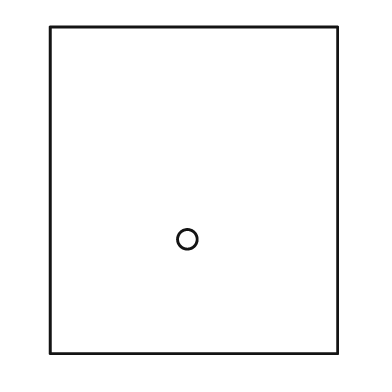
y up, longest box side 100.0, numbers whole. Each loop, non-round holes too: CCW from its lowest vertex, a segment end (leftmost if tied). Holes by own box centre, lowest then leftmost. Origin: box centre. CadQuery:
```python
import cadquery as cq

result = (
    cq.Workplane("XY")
    .moveTo(-44.0, -50.0)
    .lineTo(44.0, -50.0)
    .lineTo(44.0, 50.0)
    .lineTo(-44.0, 50.0)
    .close()
    .moveTo(-2.0, -15.0)
    .circle(3.0)
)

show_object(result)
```